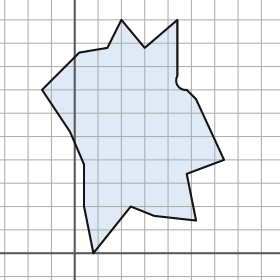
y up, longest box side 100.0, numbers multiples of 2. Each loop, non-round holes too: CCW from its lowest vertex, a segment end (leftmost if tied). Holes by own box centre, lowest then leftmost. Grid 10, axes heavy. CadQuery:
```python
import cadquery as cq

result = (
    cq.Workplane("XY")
    .moveTo(8.0, 0.0)
    .lineTo(24.0, 20.0)
    .lineTo(34.0, 16.0)
    .lineTo(52.0, 14.0)
    .lineTo(48.0, 34.0)
    .lineTo(64.0, 40.0)
    .lineTo(52.0, 66.0)
    .lineTo(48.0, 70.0)
    .threePointArc((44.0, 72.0), (44.0, 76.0))
    .lineTo(44.0, 100.0)
    .lineTo(30.0, 88.0)
    .lineTo(20.0, 100.0)
    .lineTo(14.0, 88.0)
    .lineTo(2.0, 86.0)
    .lineTo(-14.0, 70.0)
    .lineTo(-2.0, 52.0)
    .lineTo(4.0, 38.0)
    .lineTo(4.0, 20.0)
    .close()
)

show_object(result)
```